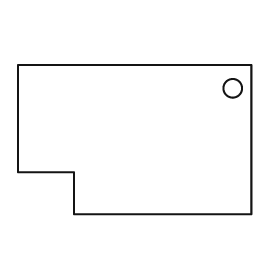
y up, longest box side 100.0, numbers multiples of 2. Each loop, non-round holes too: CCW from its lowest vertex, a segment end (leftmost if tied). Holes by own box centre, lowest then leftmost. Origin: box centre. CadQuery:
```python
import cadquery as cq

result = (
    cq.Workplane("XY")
    .moveTo(-26.0, -32.0)
    .lineTo(50.0, -32.0)
    .lineTo(50.0, 32.0)
    .lineTo(-50.0, 32.0)
    .lineTo(-50.0, -14.0)
    .lineTo(-26.0, -14.0)
    .close()
    .moveTo(42.0, 22.0)
    .circle(4.0)
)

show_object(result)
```